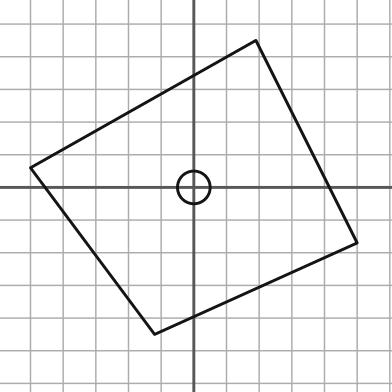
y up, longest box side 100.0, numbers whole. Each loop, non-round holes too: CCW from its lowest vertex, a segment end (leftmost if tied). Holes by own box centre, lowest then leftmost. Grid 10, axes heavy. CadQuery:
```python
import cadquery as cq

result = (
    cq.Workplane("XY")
    .moveTo(-12.0, -45.0)
    .lineTo(50.0, -17.0)
    .lineTo(19.0, 45.0)
    .lineTo(-50.0, 6.0)
    .close()
    .moveTo(0.0, 0.0)
    .circle(5.0)
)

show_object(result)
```